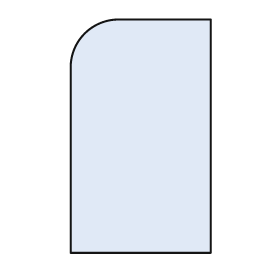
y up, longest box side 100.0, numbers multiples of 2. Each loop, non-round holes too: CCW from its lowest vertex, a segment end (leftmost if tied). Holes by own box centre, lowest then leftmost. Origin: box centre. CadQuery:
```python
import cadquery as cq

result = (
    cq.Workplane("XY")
    .moveTo(-30.0, -50.0)
    .lineTo(30.0, -50.0)
    .lineTo(30.0, 50.0)
    .lineTo(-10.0, 50.0)
    .threePointArc((-24.0, 44.0), (-30.0, 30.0))
    .close()
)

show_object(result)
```